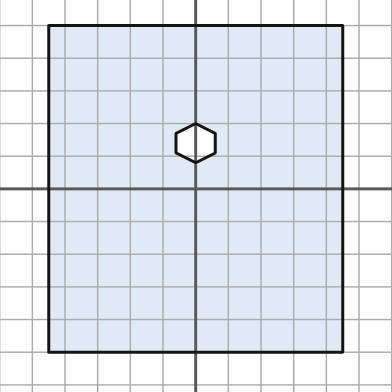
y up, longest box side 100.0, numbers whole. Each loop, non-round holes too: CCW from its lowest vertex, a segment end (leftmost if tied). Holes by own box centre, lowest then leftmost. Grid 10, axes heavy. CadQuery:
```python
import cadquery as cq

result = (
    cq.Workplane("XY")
    .moveTo(-45.0, -50.0)
    .lineTo(45.0, -50.0)
    .lineTo(45.0, 50.0)
    .lineTo(-45.0, 50.0)
    .close()
    .moveTo(0.0, 8.0)
    .lineTo(6.0, 11.0)
    .lineTo(6.0, 17.0)
    .lineTo(0.0, 20.0)
    .lineTo(-6.0, 17.0)
    .lineTo(-6.0, 11.0)
    .close()
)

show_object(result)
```